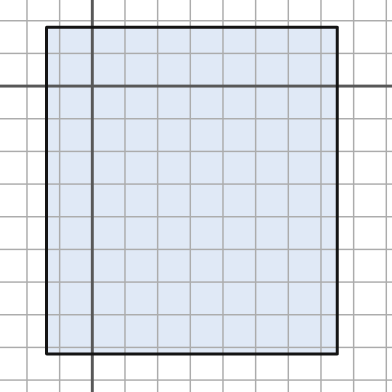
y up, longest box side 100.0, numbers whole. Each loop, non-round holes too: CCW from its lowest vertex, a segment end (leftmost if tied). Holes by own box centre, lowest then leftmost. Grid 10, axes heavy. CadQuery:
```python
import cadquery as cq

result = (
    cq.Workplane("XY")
    .moveTo(-14.0, -82.0)
    .lineTo(75.0, -82.0)
    .lineTo(75.0, 18.0)
    .lineTo(-14.0, 18.0)
    .close()
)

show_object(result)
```